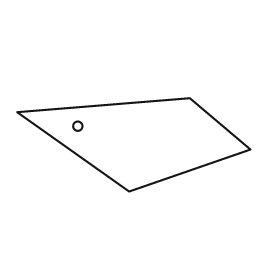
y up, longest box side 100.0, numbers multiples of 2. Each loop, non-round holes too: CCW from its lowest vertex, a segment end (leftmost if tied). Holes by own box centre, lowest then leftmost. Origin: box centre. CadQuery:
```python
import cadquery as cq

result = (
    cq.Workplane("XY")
    .moveTo(-2.0, -20.0)
    .lineTo(50.0, -2.0)
    .lineTo(24.0, 20.0)
    .lineTo(-50.0, 14.0)
    .close()
    .moveTo(-24.0, 8.0)
    .circle(2.0)
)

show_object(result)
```